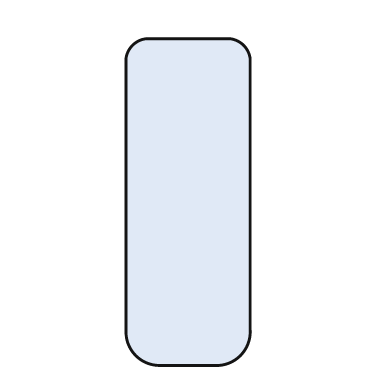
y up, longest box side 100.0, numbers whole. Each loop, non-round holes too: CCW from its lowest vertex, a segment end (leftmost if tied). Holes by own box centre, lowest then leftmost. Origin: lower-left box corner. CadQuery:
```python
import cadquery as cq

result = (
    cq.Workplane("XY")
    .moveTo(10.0, 0.0)
    .lineTo(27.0, 0.0)
    .threePointArc((35.0, 3.0), (38.0, 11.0))
    .lineTo(38.0, 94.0)
    .threePointArc((36.0, 98.0), (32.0, 100.0))
    .lineTo(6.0, 100.0)
    .threePointArc((2.0, 98.0), (0.0, 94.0))
    .lineTo(0.0, 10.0)
    .threePointArc((3.0, 3.0), (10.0, 0.0))
    .close()
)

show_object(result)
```